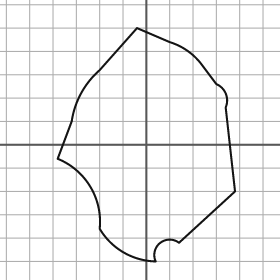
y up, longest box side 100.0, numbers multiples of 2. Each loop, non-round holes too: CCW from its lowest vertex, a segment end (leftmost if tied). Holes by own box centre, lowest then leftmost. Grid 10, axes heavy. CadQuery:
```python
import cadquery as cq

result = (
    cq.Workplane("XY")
    .moveTo(4.0, -50.0)
    .threePointArc((6.0, -42.0), (14.0, -42.0))
    .lineTo(38.0, -20.0)
    .lineTo(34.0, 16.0)
    .threePointArc((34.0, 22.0), (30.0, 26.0))
    .lineTo(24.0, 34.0)
    .threePointArc((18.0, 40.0), (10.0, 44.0))
    .lineTo(-4.0, 50.0)
    .lineTo(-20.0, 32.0)
    .threePointArc((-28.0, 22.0), (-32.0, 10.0))
    .lineTo(-38.0, -6.0)
    .threePointArc((-24.0, -18.0), (-20.0, -36.0))
    .threePointArc((-10.0, -46.0), (4.0, -50.0))
    .close()
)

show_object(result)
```